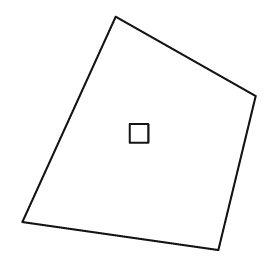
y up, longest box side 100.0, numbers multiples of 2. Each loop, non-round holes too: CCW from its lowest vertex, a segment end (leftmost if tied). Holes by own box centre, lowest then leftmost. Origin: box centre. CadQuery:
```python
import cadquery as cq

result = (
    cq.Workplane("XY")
    .moveTo(34.0, -50.0)
    .lineTo(50.0, 16.0)
    .lineTo(-10.0, 50.0)
    .lineTo(-50.0, -38.0)
    .close()
    .moveTo(-4.0, -4.0)
    .lineTo(4.0, -4.0)
    .lineTo(4.0, 4.0)
    .lineTo(-4.0, 4.0)
    .close()
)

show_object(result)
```